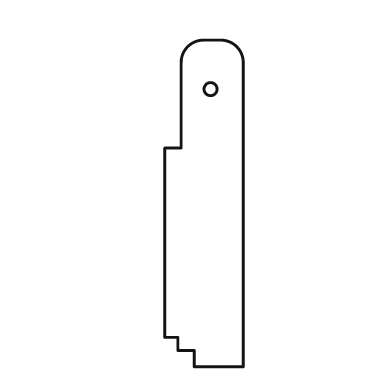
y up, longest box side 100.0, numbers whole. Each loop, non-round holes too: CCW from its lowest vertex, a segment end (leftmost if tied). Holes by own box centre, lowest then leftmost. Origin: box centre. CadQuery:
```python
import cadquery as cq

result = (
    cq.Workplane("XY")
    .moveTo(-3.0, -50.0)
    .lineTo(12.0, -50.0)
    .lineTo(12.0, 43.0)
    .threePointArc((10.0, 48.0), (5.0, 50.0))
    .lineTo(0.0, 50.0)
    .threePointArc((-5.0, 48.0), (-7.0, 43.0))
    .lineTo(-7.0, 17.0)
    .lineTo(-12.0, 17.0)
    .lineTo(-12.0, -41.0)
    .lineTo(-8.0, -41.0)
    .lineTo(-8.0, -45.0)
    .lineTo(-3.0, -45.0)
    .close()
    .moveTo(2.0, 35.0)
    .circle(2.0)
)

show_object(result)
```